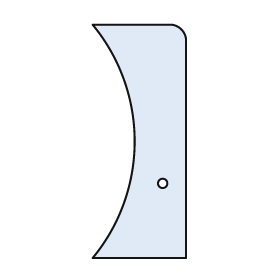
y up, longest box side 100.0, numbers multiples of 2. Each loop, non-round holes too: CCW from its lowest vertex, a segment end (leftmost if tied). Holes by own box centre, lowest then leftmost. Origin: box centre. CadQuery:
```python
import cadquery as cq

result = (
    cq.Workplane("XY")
    .moveTo(-20.0, -50.0)
    .lineTo(20.0, -50.0)
    .lineTo(20.0, 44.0)
    .threePointArc((18.0, 48.0), (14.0, 50.0))
    .lineTo(-20.0, 50.0)
    .threePointArc((-2.0, 0.0), (-20.0, -50.0))
    .close()
    .moveTo(10.0, -18.0)
    .circle(2.0)
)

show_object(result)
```